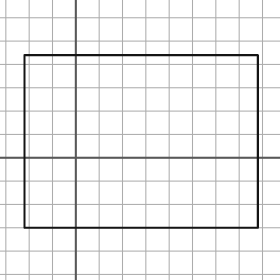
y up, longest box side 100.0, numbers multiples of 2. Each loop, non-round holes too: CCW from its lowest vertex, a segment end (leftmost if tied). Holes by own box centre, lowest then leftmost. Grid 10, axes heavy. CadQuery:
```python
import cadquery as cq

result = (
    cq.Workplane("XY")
    .moveTo(-22.0, -30.0)
    .lineTo(78.0, -30.0)
    .lineTo(78.0, 44.0)
    .lineTo(-22.0, 44.0)
    .close()
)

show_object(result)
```